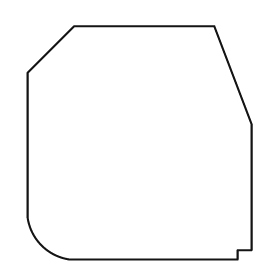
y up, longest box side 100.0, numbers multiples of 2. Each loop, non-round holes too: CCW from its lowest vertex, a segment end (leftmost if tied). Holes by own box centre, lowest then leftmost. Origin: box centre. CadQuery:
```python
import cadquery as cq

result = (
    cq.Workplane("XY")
    .moveTo(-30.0, -50.0)
    .lineTo(42.0, -50.0)
    .lineTo(42.0, -46.0)
    .lineTo(48.0, -46.0)
    .lineTo(48.0, 8.0)
    .lineTo(32.0, 50.0)
    .lineTo(-28.0, 50.0)
    .lineTo(-48.0, 30.0)
    .lineTo(-48.0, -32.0)
    .threePointArc((-42.0, -44.0), (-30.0, -50.0))
    .close()
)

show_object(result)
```